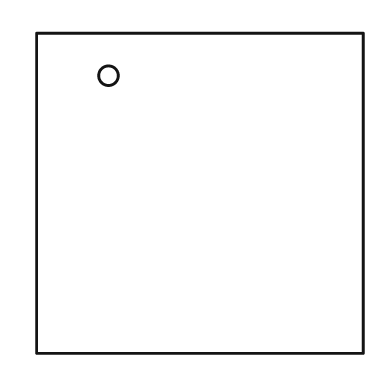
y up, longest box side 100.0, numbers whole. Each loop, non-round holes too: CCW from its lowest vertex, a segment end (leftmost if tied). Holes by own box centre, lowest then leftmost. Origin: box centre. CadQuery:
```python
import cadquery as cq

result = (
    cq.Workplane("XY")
    .moveTo(-50.0, -49.0)
    .lineTo(50.0, -49.0)
    .lineTo(50.0, 49.0)
    .lineTo(-50.0, 49.0)
    .close()
    .moveTo(-28.0, 36.0)
    .circle(3.0)
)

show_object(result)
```